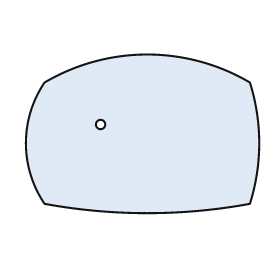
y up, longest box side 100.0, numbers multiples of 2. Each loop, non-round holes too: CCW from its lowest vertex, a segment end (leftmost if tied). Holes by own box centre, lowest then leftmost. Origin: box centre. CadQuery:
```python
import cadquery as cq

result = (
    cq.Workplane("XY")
    .moveTo(-42.0, -30.0)
    .threePointArc((2.0, -34.0), (46.0, -30.0))
    .threePointArc((50.0, -4.0), (46.0, 22.0))
    .threePointArc((2.0, 34.0), (-42.0, 22.0))
    .threePointArc((-50.0, -4.0), (-42.0, -30.0))
    .close()
    .moveTo(-18.0, 4.0)
    .circle(2.0)
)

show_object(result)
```